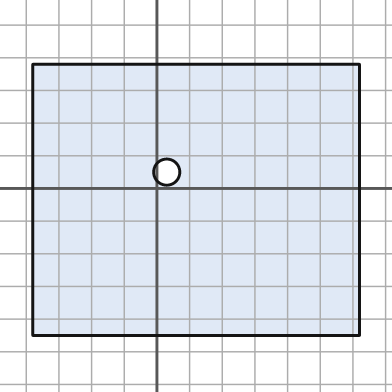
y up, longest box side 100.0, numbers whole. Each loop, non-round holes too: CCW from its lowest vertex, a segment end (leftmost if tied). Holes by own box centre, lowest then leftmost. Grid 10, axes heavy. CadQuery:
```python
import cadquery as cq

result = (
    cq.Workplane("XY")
    .moveTo(-38.0, -45.0)
    .lineTo(62.0, -45.0)
    .lineTo(62.0, 38.0)
    .lineTo(-38.0, 38.0)
    .close()
    .moveTo(3.0, 5.0)
    .circle(4.0)
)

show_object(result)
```